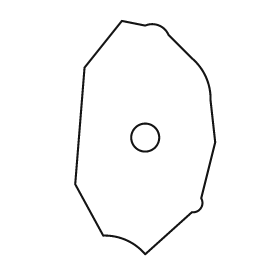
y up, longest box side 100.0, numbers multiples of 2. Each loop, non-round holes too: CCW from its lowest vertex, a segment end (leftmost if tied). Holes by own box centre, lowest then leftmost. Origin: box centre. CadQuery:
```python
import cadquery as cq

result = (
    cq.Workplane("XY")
    .moveTo(0.0, -50.0)
    .lineTo(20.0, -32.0)
    .threePointArc((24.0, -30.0), (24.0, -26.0))
    .lineTo(30.0, -2.0)
    .lineTo(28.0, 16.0)
    .threePointArc((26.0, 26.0), (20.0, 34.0))
    .lineTo(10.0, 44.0)
    .threePointArc((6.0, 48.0), (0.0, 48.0))
    .lineTo(-10.0, 50.0)
    .lineTo(-26.0, 30.0)
    .lineTo(-30.0, -20.0)
    .lineTo(-18.0, -42.0)
    .threePointArc((-8.0, -44.0), (0.0, -50.0))
    .close()
    .moveTo(0.0, 0.0)
    .circle(6.0)
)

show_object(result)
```